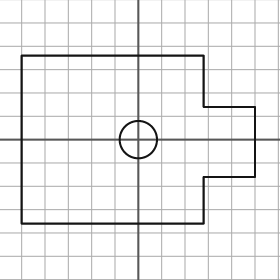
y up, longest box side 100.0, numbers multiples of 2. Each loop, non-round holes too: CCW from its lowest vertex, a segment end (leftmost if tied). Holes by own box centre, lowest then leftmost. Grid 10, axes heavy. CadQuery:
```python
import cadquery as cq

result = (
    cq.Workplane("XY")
    .moveTo(-50.0, -36.0)
    .lineTo(28.0, -36.0)
    .lineTo(28.0, -16.0)
    .lineTo(50.0, -16.0)
    .lineTo(50.0, 14.0)
    .lineTo(28.0, 14.0)
    .lineTo(28.0, 36.0)
    .lineTo(-50.0, 36.0)
    .close()
    .moveTo(0.0, 0.0)
    .circle(8.0)
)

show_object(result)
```